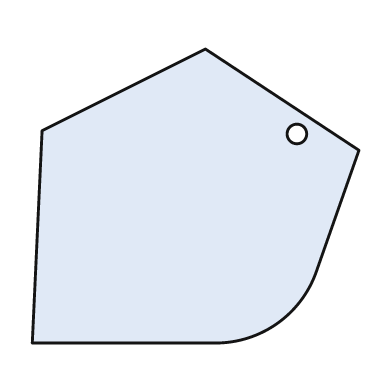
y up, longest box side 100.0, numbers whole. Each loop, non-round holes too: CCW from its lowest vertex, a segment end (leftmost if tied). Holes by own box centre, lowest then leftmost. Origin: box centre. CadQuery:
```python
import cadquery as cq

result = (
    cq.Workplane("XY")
    .moveTo(-50.0, -45.0)
    .lineTo(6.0, -45.0)
    .threePointArc((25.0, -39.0), (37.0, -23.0))
    .lineTo(50.0, 14.0)
    .lineTo(3.0, 45.0)
    .lineTo(-47.0, 20.0)
    .close()
    .moveTo(31.0, 19.0)
    .circle(3.0)
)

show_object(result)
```